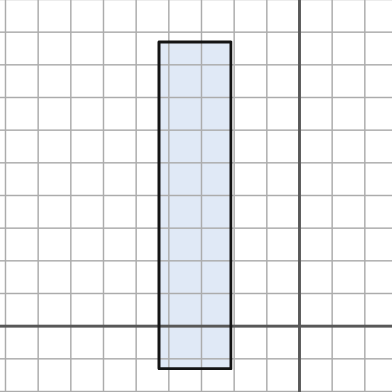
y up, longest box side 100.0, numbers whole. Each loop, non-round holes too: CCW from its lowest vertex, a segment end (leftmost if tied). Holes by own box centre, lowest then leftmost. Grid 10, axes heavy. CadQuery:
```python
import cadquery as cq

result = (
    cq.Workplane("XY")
    .moveTo(-43.0, -13.0)
    .lineTo(-21.0, -13.0)
    .lineTo(-21.0, 87.0)
    .lineTo(-43.0, 87.0)
    .close()
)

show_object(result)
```